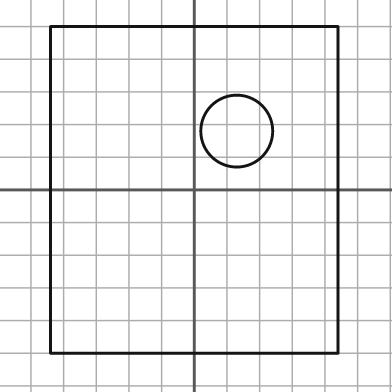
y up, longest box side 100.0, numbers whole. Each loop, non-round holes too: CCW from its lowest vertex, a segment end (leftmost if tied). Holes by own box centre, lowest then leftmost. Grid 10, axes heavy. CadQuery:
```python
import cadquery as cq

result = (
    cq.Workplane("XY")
    .moveTo(-44.0, -50.0)
    .lineTo(44.0, -50.0)
    .lineTo(44.0, 50.0)
    .lineTo(-44.0, 50.0)
    .close()
    .moveTo(13.0, 18.0)
    .circle(11.0)
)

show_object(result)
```